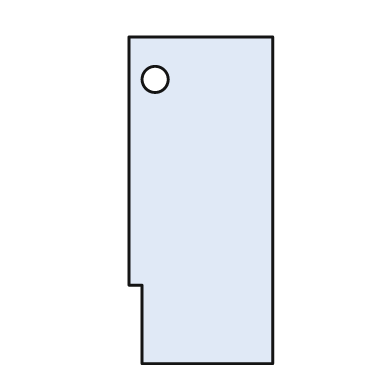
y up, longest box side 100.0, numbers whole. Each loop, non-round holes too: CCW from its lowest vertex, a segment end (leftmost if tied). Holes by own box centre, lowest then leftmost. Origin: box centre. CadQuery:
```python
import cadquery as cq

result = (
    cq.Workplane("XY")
    .moveTo(-18.0, -50.0)
    .lineTo(22.0, -50.0)
    .lineTo(22.0, 50.0)
    .lineTo(-22.0, 50.0)
    .lineTo(-22.0, -26.0)
    .lineTo(-18.0, -26.0)
    .close()
    .moveTo(-14.0, 37.0)
    .circle(4.0)
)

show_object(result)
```